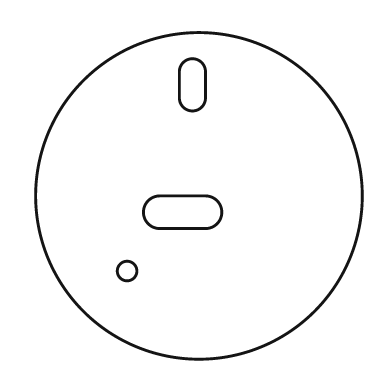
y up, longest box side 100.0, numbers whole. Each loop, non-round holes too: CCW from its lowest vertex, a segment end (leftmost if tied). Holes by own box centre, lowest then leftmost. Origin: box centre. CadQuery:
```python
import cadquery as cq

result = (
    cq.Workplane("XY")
    .moveTo(0.0, 0.0)
    .circle(50.0)
    .moveTo(-22.0, -23.0)
    .circle(3.0)
    .moveTo(-12.0, -10.0)
    .lineTo(2.0, -10.0)
    .threePointArc((7.0, -5.0), (2.0, 0.0))
    .lineTo(-12.0, 0.0)
    .threePointArc((-17.0, -5.0), (-12.0, -10.0))
    .close()
    .moveTo(-6.0, 30.0)
    .threePointArc((-2.0, 26.0), (2.0, 30.0))
    .lineTo(2.0, 38.0)
    .threePointArc((-2.0, 42.0), (-6.0, 38.0))
    .close()
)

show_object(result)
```